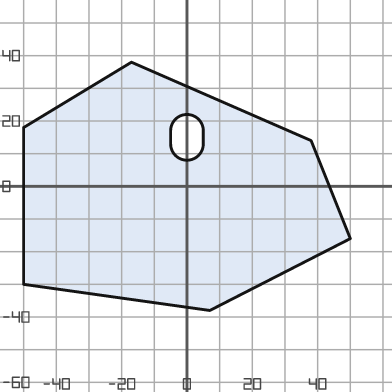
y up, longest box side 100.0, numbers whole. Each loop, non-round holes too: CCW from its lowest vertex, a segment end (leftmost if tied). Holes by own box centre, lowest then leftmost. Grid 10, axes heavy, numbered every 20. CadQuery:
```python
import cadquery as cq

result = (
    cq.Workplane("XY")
    .moveTo(7.0, -38.0)
    .lineTo(50.0, -16.0)
    .lineTo(38.0, 14.0)
    .lineTo(-17.0, 38.0)
    .lineTo(-50.0, 18.0)
    .lineTo(-50.0, -30.0)
    .close()
    .moveTo(-5.0, 13.0)
    .threePointArc((0.0, 8.0), (5.0, 13.0))
    .lineTo(5.0, 17.0)
    .threePointArc((0.0, 22.0), (-5.0, 17.0))
    .close()
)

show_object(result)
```